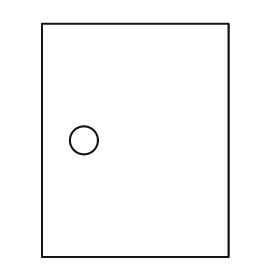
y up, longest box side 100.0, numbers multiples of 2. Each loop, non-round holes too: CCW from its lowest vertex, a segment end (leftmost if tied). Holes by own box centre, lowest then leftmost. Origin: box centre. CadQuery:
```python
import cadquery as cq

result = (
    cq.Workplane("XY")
    .moveTo(-40.0, -50.0)
    .lineTo(40.0, -50.0)
    .lineTo(40.0, 50.0)
    .lineTo(-40.0, 50.0)
    .close()
    .moveTo(-22.0, 0.0)
    .circle(6.0)
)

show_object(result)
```